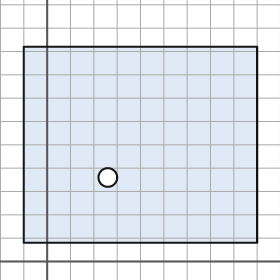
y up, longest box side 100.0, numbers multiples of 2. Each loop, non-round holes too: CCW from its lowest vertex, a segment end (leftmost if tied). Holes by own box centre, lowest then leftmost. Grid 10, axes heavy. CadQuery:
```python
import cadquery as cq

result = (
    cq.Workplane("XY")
    .moveTo(-10.0, 8.0)
    .lineTo(90.0, 8.0)
    .lineTo(90.0, 92.0)
    .lineTo(-10.0, 92.0)
    .close()
    .moveTo(26.0, 36.0)
    .circle(4.0)
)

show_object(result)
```